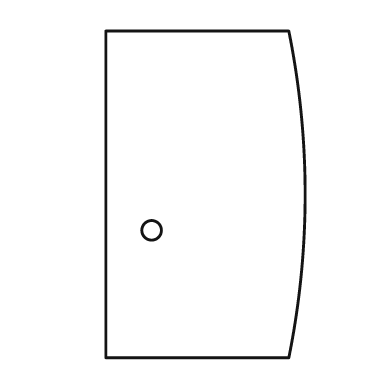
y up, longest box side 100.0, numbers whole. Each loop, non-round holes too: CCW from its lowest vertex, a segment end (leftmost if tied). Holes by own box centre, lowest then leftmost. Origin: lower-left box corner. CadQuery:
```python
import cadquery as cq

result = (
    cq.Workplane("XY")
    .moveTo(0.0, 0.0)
    .lineTo(56.0, 0.0)
    .threePointArc((61.0, 50.0), (56.0, 100.0))
    .lineTo(0.0, 100.0)
    .close()
    .moveTo(14.0, 39.0)
    .circle(3.0)
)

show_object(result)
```